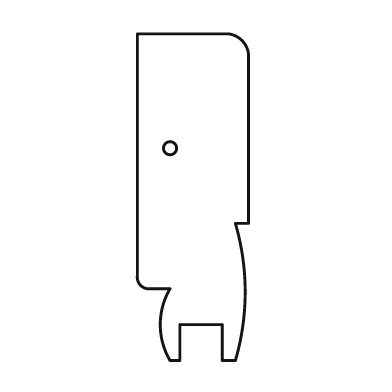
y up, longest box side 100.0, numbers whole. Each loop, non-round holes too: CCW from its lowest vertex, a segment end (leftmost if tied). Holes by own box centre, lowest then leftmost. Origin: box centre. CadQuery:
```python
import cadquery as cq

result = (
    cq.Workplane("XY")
    .moveTo(-7.0, -50.0)
    .lineTo(-4.0, -50.0)
    .lineTo(-4.0, -39.0)
    .lineTo(9.0, -39.0)
    .lineTo(9.0, -50.0)
    .lineTo(13.0, -50.0)
    .threePointArc((16.0, -29.0), (13.0, -8.0))
    .lineTo(17.0, -8.0)
    .lineTo(17.0, 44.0)
    .threePointArc((15.0, 48.0), (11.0, 50.0))
    .lineTo(-17.0, 50.0)
    .lineTo(-17.0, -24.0)
    .threePointArc((-16.0, -27.0), (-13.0, -28.0))
    .lineTo(-7.0, -28.0)
    .threePointArc((-10.0, -39.0), (-7.0, -50.0))
    .close()
    .moveTo(-7.0, 15.0)
    .circle(2.0)
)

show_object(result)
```